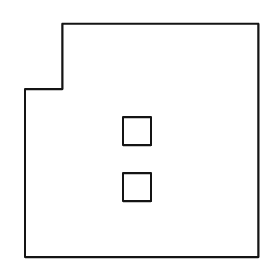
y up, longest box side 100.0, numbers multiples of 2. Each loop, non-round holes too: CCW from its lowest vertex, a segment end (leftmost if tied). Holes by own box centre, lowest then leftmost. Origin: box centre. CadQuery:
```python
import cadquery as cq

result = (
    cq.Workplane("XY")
    .moveTo(-50.0, -50.0)
    .lineTo(50.0, -50.0)
    .lineTo(50.0, 50.0)
    .lineTo(-34.0, 50.0)
    .lineTo(-34.0, 22.0)
    .lineTo(-50.0, 22.0)
    .close()
    .moveTo(-8.0, -26.0)
    .lineTo(4.0, -26.0)
    .lineTo(4.0, -14.0)
    .lineTo(-8.0, -14.0)
    .close()
    .moveTo(-8.0, -2.0)
    .lineTo(4.0, -2.0)
    .lineTo(4.0, 10.0)
    .lineTo(-8.0, 10.0)
    .close()
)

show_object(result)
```